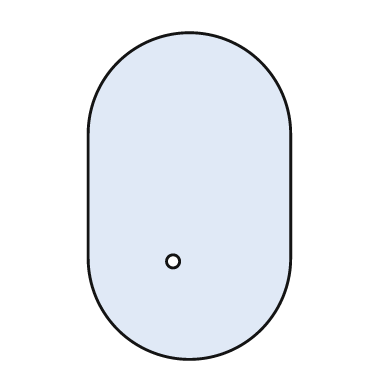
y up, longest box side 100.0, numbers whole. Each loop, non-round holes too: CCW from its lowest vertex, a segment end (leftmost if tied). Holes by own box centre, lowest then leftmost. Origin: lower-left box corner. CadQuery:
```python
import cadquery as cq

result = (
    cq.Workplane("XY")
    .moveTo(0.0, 31.0)
    .threePointArc((31.0, 0.0), (62.0, 31.0))
    .lineTo(62.0, 69.0)
    .threePointArc((31.0, 100.0), (0.0, 69.0))
    .close()
    .moveTo(26.0, 30.0)
    .circle(2.0)
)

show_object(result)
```